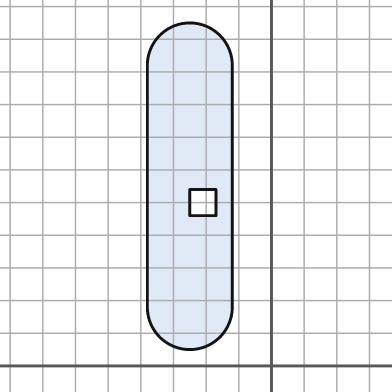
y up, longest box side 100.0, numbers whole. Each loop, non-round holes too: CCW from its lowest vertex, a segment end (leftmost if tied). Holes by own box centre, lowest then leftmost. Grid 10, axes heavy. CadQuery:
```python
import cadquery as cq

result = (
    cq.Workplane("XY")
    .moveTo(-38.0, 18.0)
    .threePointArc((-25.0, 5.0), (-12.0, 18.0))
    .lineTo(-12.0, 92.0)
    .threePointArc((-25.0, 105.0), (-38.0, 92.0))
    .close()
    .moveTo(-25.0, 46.0)
    .lineTo(-17.0, 46.0)
    .lineTo(-17.0, 54.0)
    .lineTo(-25.0, 54.0)
    .close()
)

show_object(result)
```